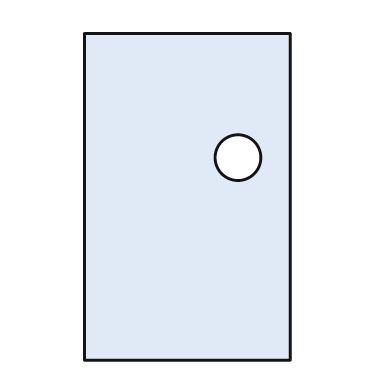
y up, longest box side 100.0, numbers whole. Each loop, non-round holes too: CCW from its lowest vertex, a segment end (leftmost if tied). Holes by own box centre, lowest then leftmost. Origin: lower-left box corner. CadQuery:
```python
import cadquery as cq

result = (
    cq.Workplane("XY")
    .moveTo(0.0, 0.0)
    .lineTo(63.0, 0.0)
    .lineTo(63.0, 100.0)
    .lineTo(0.0, 100.0)
    .close()
    .moveTo(47.0, 62.0)
    .circle(7.0)
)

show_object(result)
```